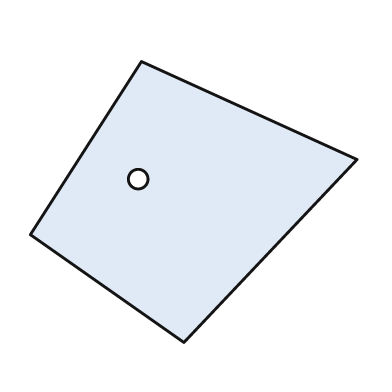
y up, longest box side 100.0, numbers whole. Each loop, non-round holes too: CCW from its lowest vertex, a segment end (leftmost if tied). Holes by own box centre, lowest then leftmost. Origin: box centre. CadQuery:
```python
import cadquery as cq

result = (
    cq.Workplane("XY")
    .moveTo(-3.0, -43.0)
    .lineTo(50.0, 13.0)
    .lineTo(-16.0, 43.0)
    .lineTo(-50.0, -10.0)
    .close()
    .moveTo(-17.0, 7.0)
    .circle(3.0)
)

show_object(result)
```